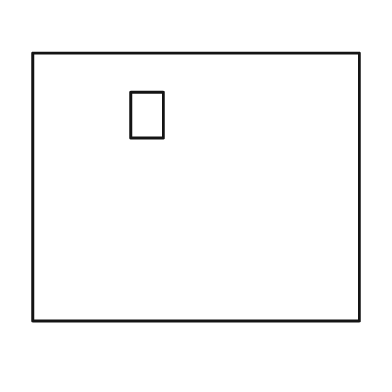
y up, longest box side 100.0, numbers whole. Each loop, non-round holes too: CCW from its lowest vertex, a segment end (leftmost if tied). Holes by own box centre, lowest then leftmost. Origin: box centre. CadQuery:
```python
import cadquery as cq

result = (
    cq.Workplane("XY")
    .moveTo(-50.0, -41.0)
    .lineTo(50.0, -41.0)
    .lineTo(50.0, 41.0)
    .lineTo(-50.0, 41.0)
    .close()
    .moveTo(-20.0, 15.0)
    .lineTo(-10.0, 15.0)
    .lineTo(-10.0, 29.0)
    .lineTo(-20.0, 29.0)
    .close()
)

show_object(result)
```